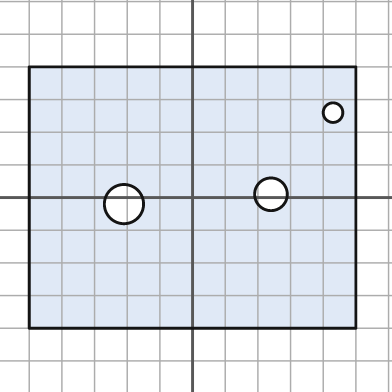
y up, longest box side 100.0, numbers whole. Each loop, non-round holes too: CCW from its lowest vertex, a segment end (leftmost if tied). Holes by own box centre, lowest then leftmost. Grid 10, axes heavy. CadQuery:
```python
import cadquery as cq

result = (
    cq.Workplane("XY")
    .moveTo(-50.0, -40.0)
    .lineTo(50.0, -40.0)
    .lineTo(50.0, 40.0)
    .lineTo(-50.0, 40.0)
    .close()
    .moveTo(-21.0, -2.0)
    .circle(6.0)
    .moveTo(24.0, 1.0)
    .circle(5.0)
    .moveTo(43.0, 26.0)
    .circle(3.0)
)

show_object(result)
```